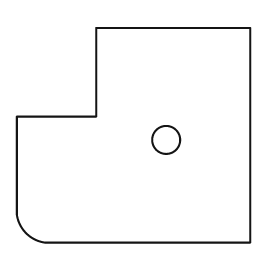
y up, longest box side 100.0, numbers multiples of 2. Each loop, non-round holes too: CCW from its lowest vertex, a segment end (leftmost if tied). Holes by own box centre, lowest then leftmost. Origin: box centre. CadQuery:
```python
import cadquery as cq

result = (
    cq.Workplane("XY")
    .moveTo(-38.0, -46.0)
    .lineTo(50.0, -46.0)
    .lineTo(50.0, 46.0)
    .lineTo(-16.0, 46.0)
    .lineTo(-16.0, 8.0)
    .lineTo(-50.0, 8.0)
    .lineTo(-50.0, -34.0)
    .threePointArc((-46.0, -42.0), (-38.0, -46.0))
    .close()
    .moveTo(14.0, -2.0)
    .circle(6.0)
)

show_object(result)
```